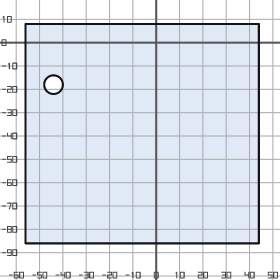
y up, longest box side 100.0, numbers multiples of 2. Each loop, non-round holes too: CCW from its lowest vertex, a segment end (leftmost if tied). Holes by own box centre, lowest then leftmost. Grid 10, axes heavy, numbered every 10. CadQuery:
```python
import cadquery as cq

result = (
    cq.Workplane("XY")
    .moveTo(-56.0, -86.0)
    .lineTo(44.0, -86.0)
    .lineTo(44.0, 8.0)
    .lineTo(-56.0, 8.0)
    .close()
    .moveTo(-44.0, -18.0)
    .circle(4.0)
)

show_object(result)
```